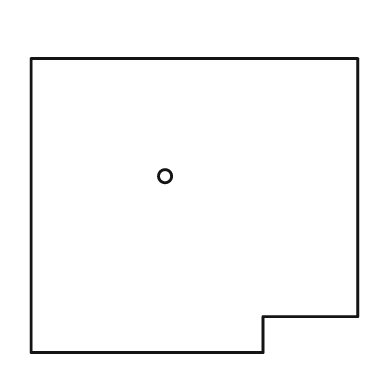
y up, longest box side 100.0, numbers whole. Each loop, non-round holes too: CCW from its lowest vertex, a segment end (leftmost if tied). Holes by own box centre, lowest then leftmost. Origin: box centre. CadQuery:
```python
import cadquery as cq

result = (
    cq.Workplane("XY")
    .moveTo(-50.0, -45.0)
    .lineTo(21.0, -45.0)
    .lineTo(21.0, -34.0)
    .lineTo(50.0, -34.0)
    .lineTo(50.0, 45.0)
    .lineTo(-50.0, 45.0)
    .close()
    .moveTo(-9.0, 9.0)
    .circle(2.0)
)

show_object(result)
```